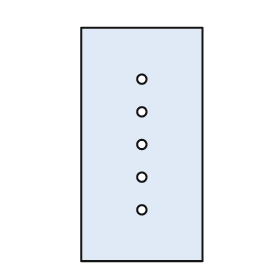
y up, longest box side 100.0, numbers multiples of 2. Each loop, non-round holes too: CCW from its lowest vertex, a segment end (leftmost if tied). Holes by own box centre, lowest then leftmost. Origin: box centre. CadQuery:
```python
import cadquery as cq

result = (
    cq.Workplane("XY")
    .moveTo(-26.0, -50.0)
    .lineTo(26.0, -50.0)
    .lineTo(26.0, 50.0)
    .lineTo(-26.0, 50.0)
    .close()
    .moveTo(0.0, -28.0)
    .circle(2.0)
    .moveTo(0.0, -14.0)
    .circle(2.0)
    .moveTo(0.0, 0.0)
    .circle(2.0)
    .moveTo(0.0, 14.0)
    .circle(2.0)
    .moveTo(0.0, 28.0)
    .circle(2.0)
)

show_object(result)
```